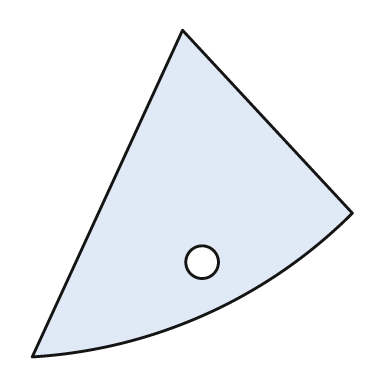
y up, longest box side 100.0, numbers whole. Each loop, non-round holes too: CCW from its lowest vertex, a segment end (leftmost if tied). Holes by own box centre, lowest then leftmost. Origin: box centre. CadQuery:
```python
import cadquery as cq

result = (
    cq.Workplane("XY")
    .moveTo(-49.0, -50.0)
    .threePointArc((4.0, -37.0), (49.0, -6.0))
    .lineTo(-3.0, 50.0)
    .close()
    .moveTo(3.0, -21.0)
    .circle(5.0)
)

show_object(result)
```